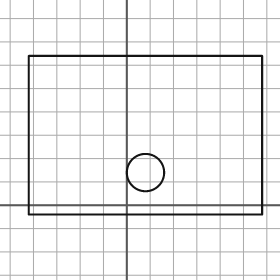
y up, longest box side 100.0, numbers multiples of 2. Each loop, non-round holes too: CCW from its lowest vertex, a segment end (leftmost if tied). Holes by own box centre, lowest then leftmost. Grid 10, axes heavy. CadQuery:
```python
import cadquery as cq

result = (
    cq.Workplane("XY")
    .moveTo(-42.0, -4.0)
    .lineTo(58.0, -4.0)
    .lineTo(58.0, 64.0)
    .lineTo(-42.0, 64.0)
    .close()
    .moveTo(8.0, 14.0)
    .circle(8.0)
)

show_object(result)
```